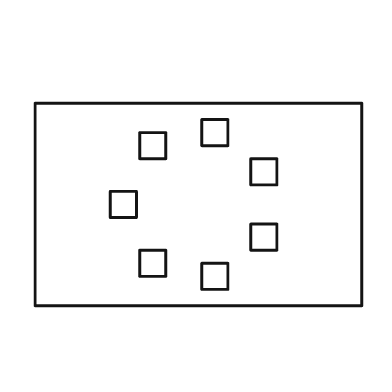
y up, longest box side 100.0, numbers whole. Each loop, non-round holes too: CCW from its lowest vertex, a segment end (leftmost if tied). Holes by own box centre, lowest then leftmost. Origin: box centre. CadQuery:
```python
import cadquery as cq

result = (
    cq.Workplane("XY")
    .moveTo(-50.0, -31.0)
    .lineTo(50.0, -31.0)
    .lineTo(50.0, 31.0)
    .lineTo(-50.0, 31.0)
    .close()
    .moveTo(1.0, -26.0)
    .lineTo(9.0, -26.0)
    .lineTo(9.0, -18.0)
    .lineTo(1.0, -18.0)
    .close()
    .moveTo(-18.0, -22.0)
    .lineTo(-10.0, -22.0)
    .lineTo(-10.0, -14.0)
    .lineTo(-18.0, -14.0)
    .close()
    .moveTo(16.0, -14.0)
    .lineTo(24.0, -14.0)
    .lineTo(24.0, -6.0)
    .lineTo(16.0, -6.0)
    .close()
    .moveTo(-27.0, -4.0)
    .lineTo(-19.0, -4.0)
    .lineTo(-19.0, 4.0)
    .lineTo(-27.0, 4.0)
    .close()
    .moveTo(16.0, 6.0)
    .lineTo(24.0, 6.0)
    .lineTo(24.0, 14.0)
    .lineTo(16.0, 14.0)
    .close()
    .moveTo(-18.0, 14.0)
    .lineTo(-10.0, 14.0)
    .lineTo(-10.0, 22.0)
    .lineTo(-18.0, 22.0)
    .close()
    .moveTo(1.0, 18.0)
    .lineTo(9.0, 18.0)
    .lineTo(9.0, 26.0)
    .lineTo(1.0, 26.0)
    .close()
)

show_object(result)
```